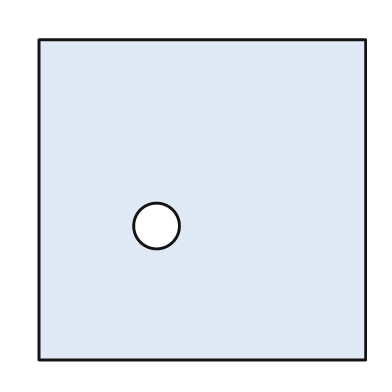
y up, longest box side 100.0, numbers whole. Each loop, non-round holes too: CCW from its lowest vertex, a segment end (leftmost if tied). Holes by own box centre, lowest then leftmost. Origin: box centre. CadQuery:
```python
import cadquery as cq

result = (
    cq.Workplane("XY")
    .moveTo(-50.0, -49.0)
    .lineTo(50.0, -49.0)
    .lineTo(50.0, 49.0)
    .lineTo(-50.0, 49.0)
    .close()
    .moveTo(-14.0, -8.0)
    .circle(7.0)
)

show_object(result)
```